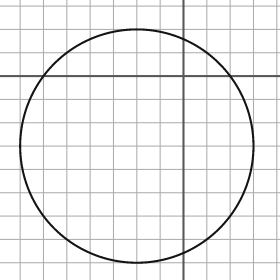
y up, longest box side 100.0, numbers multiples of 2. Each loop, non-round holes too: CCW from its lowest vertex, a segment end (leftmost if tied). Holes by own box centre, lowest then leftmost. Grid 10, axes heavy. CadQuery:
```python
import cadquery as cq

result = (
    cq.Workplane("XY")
    .moveTo(-20.0, -30.0)
    .circle(50.0)
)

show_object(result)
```